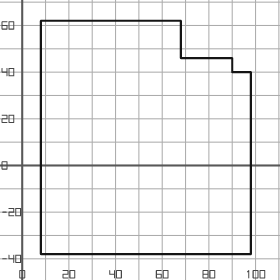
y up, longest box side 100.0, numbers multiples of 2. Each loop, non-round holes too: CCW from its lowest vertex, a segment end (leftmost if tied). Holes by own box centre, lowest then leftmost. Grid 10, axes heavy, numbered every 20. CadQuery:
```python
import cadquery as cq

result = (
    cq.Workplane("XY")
    .moveTo(8.0, -38.0)
    .lineTo(98.0, -38.0)
    .lineTo(98.0, 40.0)
    .lineTo(90.0, 40.0)
    .lineTo(90.0, 46.0)
    .lineTo(68.0, 46.0)
    .lineTo(68.0, 62.0)
    .lineTo(8.0, 62.0)
    .close()
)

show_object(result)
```